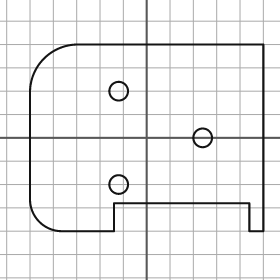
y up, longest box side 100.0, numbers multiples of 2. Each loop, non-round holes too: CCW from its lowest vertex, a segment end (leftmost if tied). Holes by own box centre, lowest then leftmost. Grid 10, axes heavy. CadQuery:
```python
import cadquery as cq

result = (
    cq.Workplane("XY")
    .moveTo(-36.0, -40.0)
    .lineTo(-14.0, -40.0)
    .lineTo(-14.0, -28.0)
    .lineTo(44.0, -28.0)
    .lineTo(44.0, -40.0)
    .lineTo(50.0, -40.0)
    .lineTo(50.0, 40.0)
    .lineTo(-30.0, 40.0)
    .threePointArc((-44.0, 34.0), (-50.0, 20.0))
    .lineTo(-50.0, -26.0)
    .threePointArc((-46.0, -36.0), (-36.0, -40.0))
    .close()
    .moveTo(-12.0, -20.0)
    .circle(4.0)
    .moveTo(24.0, 0.0)
    .circle(4.0)
    .moveTo(-12.0, 20.0)
    .circle(4.0)
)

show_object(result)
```